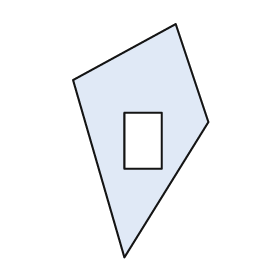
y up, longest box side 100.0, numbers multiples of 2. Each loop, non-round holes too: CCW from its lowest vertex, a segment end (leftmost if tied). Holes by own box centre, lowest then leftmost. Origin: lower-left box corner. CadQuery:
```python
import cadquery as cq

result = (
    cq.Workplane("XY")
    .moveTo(22.0, 0.0)
    .lineTo(58.0, 58.0)
    .lineTo(44.0, 100.0)
    .lineTo(0.0, 76.0)
    .close()
    .moveTo(22.0, 38.0)
    .lineTo(38.0, 38.0)
    .lineTo(38.0, 62.0)
    .lineTo(22.0, 62.0)
    .close()
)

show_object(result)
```